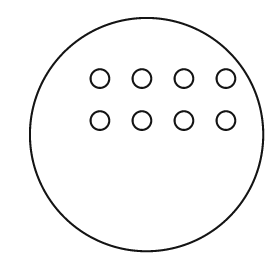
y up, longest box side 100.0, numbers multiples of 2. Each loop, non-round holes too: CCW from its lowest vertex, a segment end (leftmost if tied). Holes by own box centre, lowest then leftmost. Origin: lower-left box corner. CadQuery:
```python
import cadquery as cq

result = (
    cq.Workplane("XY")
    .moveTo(50.0, 50.0)
    .circle(50.0)
    .moveTo(30.0, 56.0)
    .circle(4.0)
    .moveTo(48.0, 56.0)
    .circle(4.0)
    .moveTo(66.0, 56.0)
    .circle(4.0)
    .moveTo(84.0, 56.0)
    .circle(4.0)
    .moveTo(30.0, 74.0)
    .circle(4.0)
    .moveTo(48.0, 74.0)
    .circle(4.0)
    .moveTo(66.0, 74.0)
    .circle(4.0)
    .moveTo(84.0, 74.0)
    .circle(4.0)
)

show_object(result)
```